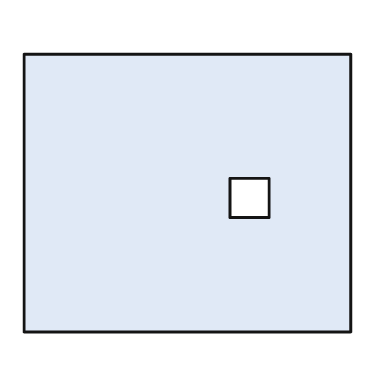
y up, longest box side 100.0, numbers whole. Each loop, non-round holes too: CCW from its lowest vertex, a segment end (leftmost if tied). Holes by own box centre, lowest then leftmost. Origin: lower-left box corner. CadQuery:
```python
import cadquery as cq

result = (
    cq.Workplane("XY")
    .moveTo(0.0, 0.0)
    .lineTo(100.0, 0.0)
    .lineTo(100.0, 85.0)
    .lineTo(0.0, 85.0)
    .close()
    .moveTo(63.0, 35.0)
    .lineTo(75.0, 35.0)
    .lineTo(75.0, 47.0)
    .lineTo(63.0, 47.0)
    .close()
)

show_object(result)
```